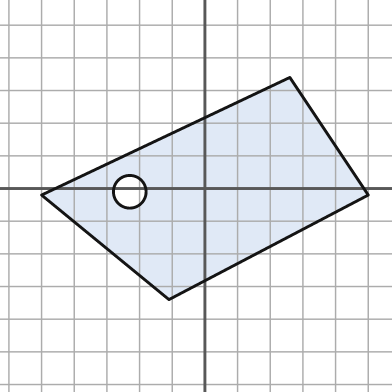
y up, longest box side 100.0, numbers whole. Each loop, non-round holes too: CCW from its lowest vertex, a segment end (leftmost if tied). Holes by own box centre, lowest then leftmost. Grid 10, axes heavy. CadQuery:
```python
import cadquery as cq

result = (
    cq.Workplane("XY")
    .moveTo(-11.0, -34.0)
    .lineTo(50.0, -2.0)
    .lineTo(26.0, 34.0)
    .lineTo(-50.0, -2.0)
    .close()
    .moveTo(-23.0, -1.0)
    .circle(5.0)
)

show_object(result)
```